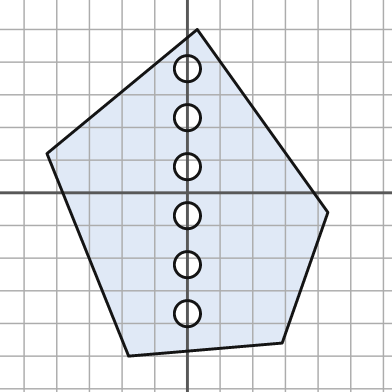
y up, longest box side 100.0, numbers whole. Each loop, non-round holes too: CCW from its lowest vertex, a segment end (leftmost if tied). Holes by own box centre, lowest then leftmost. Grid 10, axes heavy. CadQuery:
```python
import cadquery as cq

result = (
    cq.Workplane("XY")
    .moveTo(-18.0, -50.0)
    .lineTo(29.0, -46.0)
    .lineTo(43.0, -6.0)
    .lineTo(3.0, 50.0)
    .lineTo(-43.0, 12.0)
    .close()
    .moveTo(0.0, -37.0)
    .circle(4.0)
    .moveTo(0.0, -22.0)
    .circle(4.0)
    .moveTo(0.0, -7.0)
    .circle(4.0)
    .moveTo(0.0, 8.0)
    .circle(4.0)
    .moveTo(0.0, 23.0)
    .circle(4.0)
    .moveTo(0.0, 38.0)
    .circle(4.0)
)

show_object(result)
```